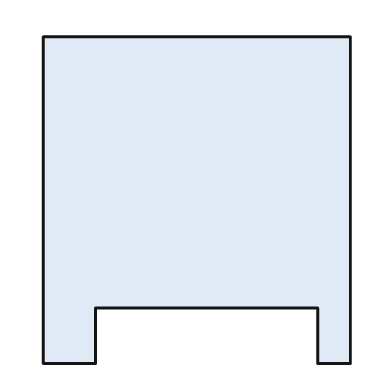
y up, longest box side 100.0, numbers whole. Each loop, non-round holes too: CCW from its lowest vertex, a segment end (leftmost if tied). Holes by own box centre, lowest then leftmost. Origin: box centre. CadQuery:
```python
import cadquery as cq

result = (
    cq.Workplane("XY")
    .moveTo(-47.0, -50.0)
    .lineTo(-31.0, -50.0)
    .lineTo(-31.0, -33.0)
    .lineTo(37.0, -33.0)
    .lineTo(37.0, -50.0)
    .lineTo(47.0, -50.0)
    .lineTo(47.0, 50.0)
    .lineTo(-47.0, 50.0)
    .close()
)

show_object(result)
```